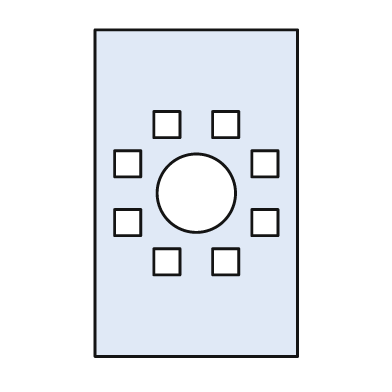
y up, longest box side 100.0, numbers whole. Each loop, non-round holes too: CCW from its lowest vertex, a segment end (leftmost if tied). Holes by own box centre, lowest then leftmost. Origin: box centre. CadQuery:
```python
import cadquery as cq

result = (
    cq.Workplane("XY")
    .moveTo(-31.0, -50.0)
    .lineTo(31.0, -50.0)
    .lineTo(31.0, 50.0)
    .lineTo(-31.0, 50.0)
    .close()
    .moveTo(-13.0, -25.0)
    .lineTo(-5.0, -25.0)
    .lineTo(-5.0, -17.0)
    .lineTo(-13.0, -17.0)
    .close()
    .moveTo(5.0, -25.0)
    .lineTo(13.0, -25.0)
    .lineTo(13.0, -17.0)
    .lineTo(5.0, -17.0)
    .close()
    .moveTo(-25.0, -13.0)
    .lineTo(-17.0, -13.0)
    .lineTo(-17.0, -5.0)
    .lineTo(-25.0, -5.0)
    .close()
    .moveTo(17.0, -13.0)
    .lineTo(25.0, -13.0)
    .lineTo(25.0, -5.0)
    .lineTo(17.0, -5.0)
    .close()
    .moveTo(0.0, 0.0)
    .circle(12.0)
    .moveTo(-25.0, 5.0)
    .lineTo(-17.0, 5.0)
    .lineTo(-17.0, 13.0)
    .lineTo(-25.0, 13.0)
    .close()
    .moveTo(17.0, 5.0)
    .lineTo(25.0, 5.0)
    .lineTo(25.0, 13.0)
    .lineTo(17.0, 13.0)
    .close()
    .moveTo(-13.0, 17.0)
    .lineTo(-5.0, 17.0)
    .lineTo(-5.0, 25.0)
    .lineTo(-13.0, 25.0)
    .close()
    .moveTo(5.0, 17.0)
    .lineTo(13.0, 17.0)
    .lineTo(13.0, 25.0)
    .lineTo(5.0, 25.0)
    .close()
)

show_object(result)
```